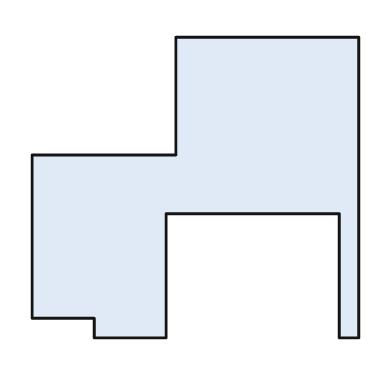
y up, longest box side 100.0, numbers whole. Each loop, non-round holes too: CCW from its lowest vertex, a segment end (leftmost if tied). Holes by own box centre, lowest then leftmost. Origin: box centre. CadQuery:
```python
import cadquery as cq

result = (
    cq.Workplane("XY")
    .moveTo(-31.0, -46.0)
    .lineTo(-9.0, -46.0)
    .lineTo(-9.0, -8.0)
    .lineTo(44.0, -8.0)
    .lineTo(44.0, -46.0)
    .lineTo(50.0, -46.0)
    .lineTo(50.0, 46.0)
    .lineTo(-6.0, 46.0)
    .lineTo(-6.0, 10.0)
    .lineTo(-50.0, 10.0)
    .lineTo(-50.0, -40.0)
    .lineTo(-31.0, -40.0)
    .close()
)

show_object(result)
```